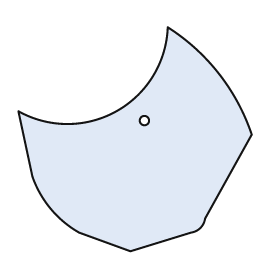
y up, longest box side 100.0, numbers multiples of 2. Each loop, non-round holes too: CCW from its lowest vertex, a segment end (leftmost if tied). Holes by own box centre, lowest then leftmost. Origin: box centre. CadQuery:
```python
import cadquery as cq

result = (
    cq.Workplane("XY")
    .moveTo(-2.0, -48.0)
    .lineTo(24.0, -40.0)
    .threePointArc((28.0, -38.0), (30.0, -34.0))
    .lineTo(50.0, 2.0)
    .threePointArc((36.0, 28.0), (14.0, 48.0))
    .threePointArc((-8.0, 12.0), (-50.0, 12.0))
    .lineTo(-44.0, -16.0)
    .threePointArc((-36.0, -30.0), (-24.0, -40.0))
    .close()
    .moveTo(4.0, 8.0)
    .circle(2.0)
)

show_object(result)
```